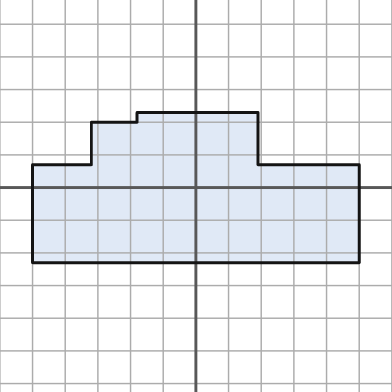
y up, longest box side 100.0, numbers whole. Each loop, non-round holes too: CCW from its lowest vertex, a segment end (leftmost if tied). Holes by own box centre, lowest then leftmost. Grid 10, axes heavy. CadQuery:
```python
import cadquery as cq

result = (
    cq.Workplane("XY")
    .moveTo(-50.0, -23.0)
    .lineTo(50.0, -23.0)
    .lineTo(50.0, 7.0)
    .lineTo(19.0, 7.0)
    .lineTo(19.0, 23.0)
    .lineTo(-18.0, 23.0)
    .lineTo(-18.0, 20.0)
    .lineTo(-32.0, 20.0)
    .lineTo(-32.0, 7.0)
    .lineTo(-50.0, 7.0)
    .close()
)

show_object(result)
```